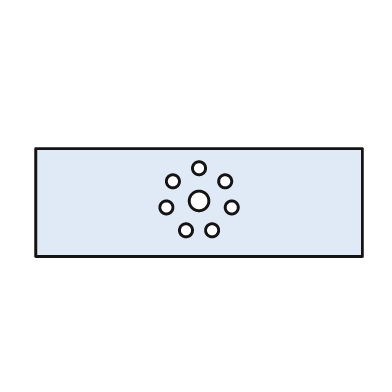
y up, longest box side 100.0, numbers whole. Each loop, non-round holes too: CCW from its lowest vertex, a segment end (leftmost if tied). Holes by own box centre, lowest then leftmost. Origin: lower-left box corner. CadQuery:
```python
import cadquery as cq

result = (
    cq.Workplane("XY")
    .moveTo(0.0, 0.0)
    .lineTo(100.0, 0.0)
    .lineTo(100.0, 33.0)
    .lineTo(0.0, 33.0)
    .close()
    .moveTo(46.0, 8.0)
    .circle(2.0)
    .moveTo(54.0, 8.0)
    .circle(2.0)
    .moveTo(40.0, 15.0)
    .circle(2.0)
    .moveTo(60.0, 15.0)
    .circle(2.0)
    .moveTo(50.0, 17.0)
    .circle(3.0)
    .moveTo(42.0, 23.0)
    .circle(2.0)
    .moveTo(58.0, 23.0)
    .circle(2.0)
    .moveTo(50.0, 27.0)
    .circle(2.0)
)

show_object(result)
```